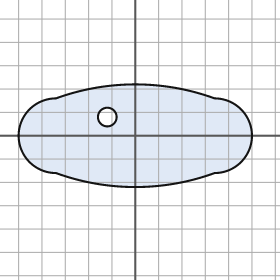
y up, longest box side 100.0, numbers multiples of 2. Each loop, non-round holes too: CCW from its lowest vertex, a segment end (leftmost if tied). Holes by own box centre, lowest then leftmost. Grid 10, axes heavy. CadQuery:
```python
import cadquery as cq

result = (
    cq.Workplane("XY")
    .moveTo(-34.0, -16.0)
    .threePointArc((0.0, -22.0), (34.0, -16.0))
    .threePointArc((50.0, 0.0), (34.0, 16.0))
    .threePointArc((0.0, 22.0), (-34.0, 16.0))
    .threePointArc((-50.0, 0.0), (-34.0, -16.0))
    .close()
    .moveTo(-12.0, 8.0)
    .circle(4.0)
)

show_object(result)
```